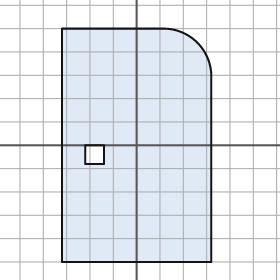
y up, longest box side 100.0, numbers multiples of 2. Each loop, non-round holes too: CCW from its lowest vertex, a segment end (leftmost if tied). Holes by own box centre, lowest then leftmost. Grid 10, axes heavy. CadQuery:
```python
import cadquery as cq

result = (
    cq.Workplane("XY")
    .moveTo(-32.0, -50.0)
    .lineTo(32.0, -50.0)
    .lineTo(32.0, 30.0)
    .threePointArc((26.0, 44.0), (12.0, 50.0))
    .lineTo(-32.0, 50.0)
    .close()
    .moveTo(-22.0, -8.0)
    .lineTo(-14.0, -8.0)
    .lineTo(-14.0, 0.0)
    .lineTo(-22.0, 0.0)
    .close()
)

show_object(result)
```